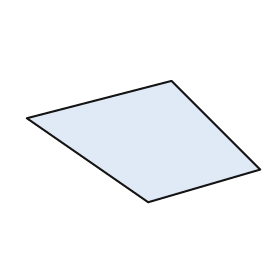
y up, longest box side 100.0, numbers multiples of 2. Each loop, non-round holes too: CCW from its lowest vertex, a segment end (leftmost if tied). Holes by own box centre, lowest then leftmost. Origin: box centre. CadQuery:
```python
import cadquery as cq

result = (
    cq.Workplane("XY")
    .moveTo(2.0, -26.0)
    .lineTo(50.0, -12.0)
    .lineTo(12.0, 26.0)
    .lineTo(-50.0, 10.0)
    .close()
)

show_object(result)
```